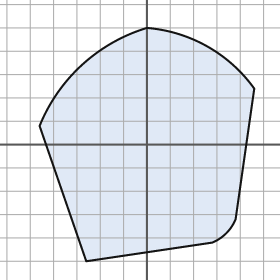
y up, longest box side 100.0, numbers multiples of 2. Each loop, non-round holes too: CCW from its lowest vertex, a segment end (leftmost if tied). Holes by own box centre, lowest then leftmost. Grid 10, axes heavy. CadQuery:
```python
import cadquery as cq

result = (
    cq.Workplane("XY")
    .moveTo(-26.0, -50.0)
    .lineTo(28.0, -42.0)
    .threePointArc((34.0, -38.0), (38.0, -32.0))
    .lineTo(46.0, 24.0)
    .threePointArc((26.0, 42.0), (0.0, 50.0))
    .threePointArc((-28.0, 34.0), (-46.0, 8.0))
    .close()
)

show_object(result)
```